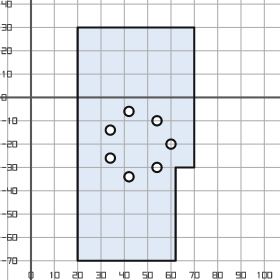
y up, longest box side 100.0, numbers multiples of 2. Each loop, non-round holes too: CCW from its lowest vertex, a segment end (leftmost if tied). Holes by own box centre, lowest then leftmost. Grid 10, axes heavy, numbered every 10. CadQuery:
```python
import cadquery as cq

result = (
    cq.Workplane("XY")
    .moveTo(20.0, -70.0)
    .lineTo(62.0, -70.0)
    .lineTo(62.0, -30.0)
    .lineTo(70.0, -30.0)
    .lineTo(70.0, 30.0)
    .lineTo(20.0, 30.0)
    .close()
    .moveTo(42.0, -34.0)
    .circle(2.0)
    .moveTo(54.0, -30.0)
    .circle(2.0)
    .moveTo(34.0, -26.0)
    .circle(2.0)
    .moveTo(60.0, -20.0)
    .circle(2.0)
    .moveTo(34.0, -14.0)
    .circle(2.0)
    .moveTo(54.0, -10.0)
    .circle(2.0)
    .moveTo(42.0, -6.0)
    .circle(2.0)
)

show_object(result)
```